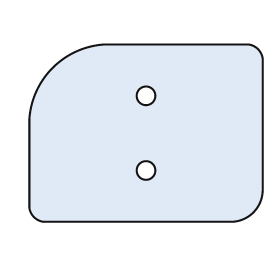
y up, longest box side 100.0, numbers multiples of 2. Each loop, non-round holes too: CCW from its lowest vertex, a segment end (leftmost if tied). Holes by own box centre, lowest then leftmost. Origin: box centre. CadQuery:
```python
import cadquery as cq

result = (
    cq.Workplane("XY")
    .moveTo(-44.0, -38.0)
    .lineTo(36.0, -38.0)
    .threePointArc((46.0, -34.0), (50.0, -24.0))
    .lineTo(50.0, 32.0)
    .threePointArc((48.0, 36.0), (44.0, 38.0))
    .lineTo(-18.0, 38.0)
    .threePointArc((-40.0, 28.0), (-50.0, 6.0))
    .lineTo(-50.0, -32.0)
    .threePointArc((-48.0, -36.0), (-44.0, -38.0))
    .close()
    .moveTo(0.0, -16.0)
    .circle(4.0)
    .moveTo(0.0, 16.0)
    .circle(4.0)
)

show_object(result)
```